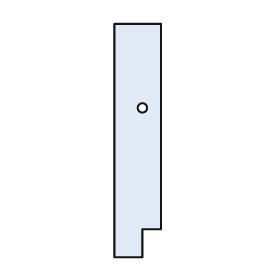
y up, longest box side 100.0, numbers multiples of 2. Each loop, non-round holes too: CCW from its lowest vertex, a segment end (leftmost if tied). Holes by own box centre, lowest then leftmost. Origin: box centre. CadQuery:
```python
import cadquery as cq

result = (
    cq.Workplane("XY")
    .moveTo(-10.0, -50.0)
    .lineTo(2.0, -50.0)
    .lineTo(2.0, -38.0)
    .lineTo(10.0, -38.0)
    .lineTo(10.0, 50.0)
    .lineTo(-10.0, 50.0)
    .close()
    .moveTo(2.0, 14.0)
    .circle(2.0)
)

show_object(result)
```